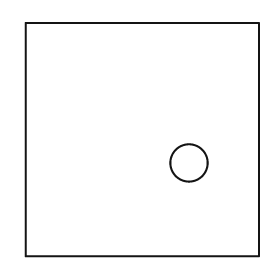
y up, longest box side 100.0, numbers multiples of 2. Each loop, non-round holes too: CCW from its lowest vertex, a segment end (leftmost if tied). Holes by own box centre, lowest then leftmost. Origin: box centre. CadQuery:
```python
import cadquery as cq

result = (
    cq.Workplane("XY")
    .moveTo(-50.0, -50.0)
    .lineTo(50.0, -50.0)
    .lineTo(50.0, 50.0)
    .lineTo(-50.0, 50.0)
    .close()
    .moveTo(20.0, -10.0)
    .circle(8.0)
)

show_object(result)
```